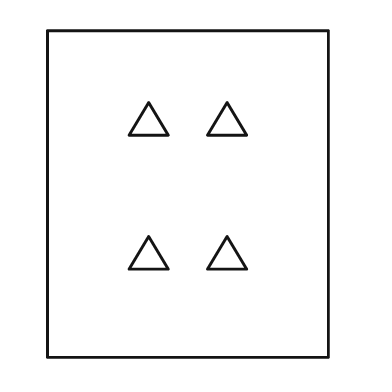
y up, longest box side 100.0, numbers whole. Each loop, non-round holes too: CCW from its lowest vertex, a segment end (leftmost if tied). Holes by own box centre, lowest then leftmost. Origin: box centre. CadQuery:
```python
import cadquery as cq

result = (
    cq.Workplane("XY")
    .moveTo(-43.0, -50.0)
    .lineTo(43.0, -50.0)
    .lineTo(43.0, 50.0)
    .lineTo(-43.0, 50.0)
    .close()
    .moveTo(-18.0, -23.0)
    .lineTo(-6.0, -23.0)
    .lineTo(-12.0, -13.0)
    .close()
    .moveTo(6.0, -23.0)
    .lineTo(18.0, -23.0)
    .lineTo(12.0, -13.0)
    .close()
    .moveTo(-18.0, 18.0)
    .lineTo(-6.0, 18.0)
    .lineTo(-12.0, 28.0)
    .close()
    .moveTo(6.0, 18.0)
    .lineTo(18.0, 18.0)
    .lineTo(12.0, 28.0)
    .close()
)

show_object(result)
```